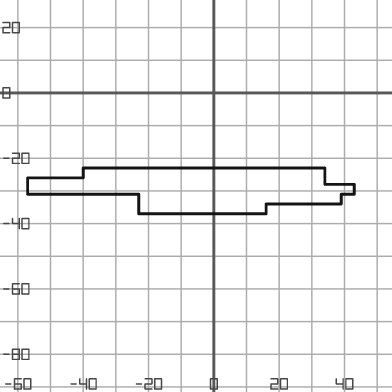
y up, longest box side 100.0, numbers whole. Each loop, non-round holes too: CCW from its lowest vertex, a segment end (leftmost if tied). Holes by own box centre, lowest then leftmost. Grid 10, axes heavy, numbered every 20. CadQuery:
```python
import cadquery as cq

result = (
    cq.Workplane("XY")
    .moveTo(-23.0, -37.0)
    .lineTo(16.0, -37.0)
    .lineTo(16.0, -34.0)
    .lineTo(39.0, -34.0)
    .lineTo(39.0, -31.0)
    .lineTo(43.0, -31.0)
    .lineTo(43.0, -28.0)
    .lineTo(34.0, -28.0)
    .lineTo(34.0, -23.0)
    .lineTo(-40.0, -23.0)
    .lineTo(-40.0, -26.0)
    .lineTo(-57.0, -26.0)
    .lineTo(-57.0, -31.0)
    .lineTo(-23.0, -31.0)
    .close()
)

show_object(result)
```